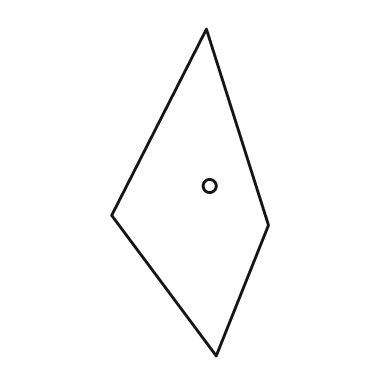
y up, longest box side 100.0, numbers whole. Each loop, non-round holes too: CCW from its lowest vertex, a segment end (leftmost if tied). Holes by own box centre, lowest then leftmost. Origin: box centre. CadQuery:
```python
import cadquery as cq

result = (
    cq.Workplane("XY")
    .moveTo(8.0, -50.0)
    .lineTo(24.0, -10.0)
    .lineTo(5.0, 50.0)
    .lineTo(-24.0, -7.0)
    .close()
    .moveTo(6.0, 2.0)
    .circle(2.0)
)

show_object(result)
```